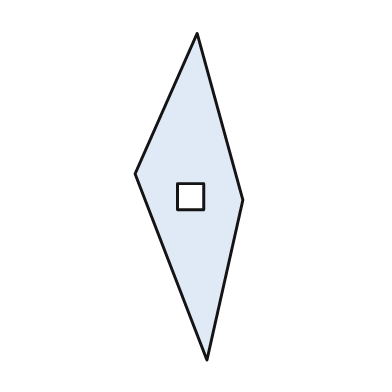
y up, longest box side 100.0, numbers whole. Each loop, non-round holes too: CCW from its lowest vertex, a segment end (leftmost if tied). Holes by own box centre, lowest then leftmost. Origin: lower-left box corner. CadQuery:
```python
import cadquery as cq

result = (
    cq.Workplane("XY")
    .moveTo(22.0, 0.0)
    .lineTo(33.0, 49.0)
    .lineTo(19.0, 100.0)
    .lineTo(0.0, 57.0)
    .close()
    .moveTo(13.0, 46.0)
    .lineTo(21.0, 46.0)
    .lineTo(21.0, 54.0)
    .lineTo(13.0, 54.0)
    .close()
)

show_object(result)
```